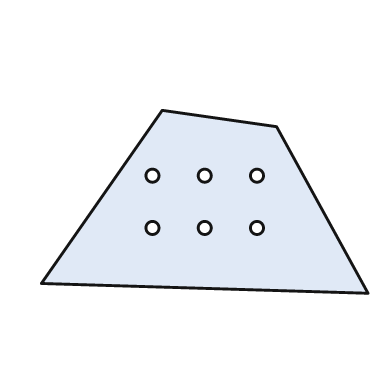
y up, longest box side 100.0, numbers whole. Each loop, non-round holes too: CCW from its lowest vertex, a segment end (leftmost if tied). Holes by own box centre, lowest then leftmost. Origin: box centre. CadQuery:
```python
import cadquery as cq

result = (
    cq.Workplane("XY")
    .moveTo(50.0, -28.0)
    .lineTo(22.0, 23.0)
    .lineTo(-13.0, 28.0)
    .lineTo(-50.0, -25.0)
    .close()
    .moveTo(-16.0, -8.0)
    .circle(2.0)
    .moveTo(0.0, -8.0)
    .circle(2.0)
    .moveTo(16.0, -8.0)
    .circle(2.0)
    .moveTo(-16.0, 8.0)
    .circle(2.0)
    .moveTo(0.0, 8.0)
    .circle(2.0)
    .moveTo(16.0, 8.0)
    .circle(2.0)
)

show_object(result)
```